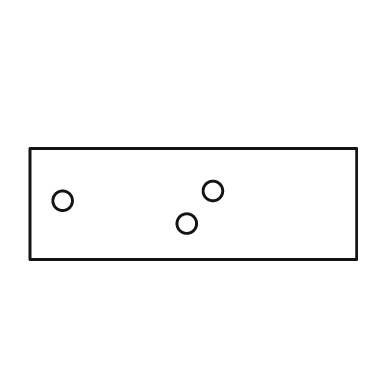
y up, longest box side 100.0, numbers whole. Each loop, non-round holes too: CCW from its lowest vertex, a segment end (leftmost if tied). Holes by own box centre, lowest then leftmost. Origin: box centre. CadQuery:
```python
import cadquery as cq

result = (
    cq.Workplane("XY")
    .moveTo(-50.0, -17.0)
    .lineTo(50.0, -17.0)
    .lineTo(50.0, 17.0)
    .lineTo(-50.0, 17.0)
    .close()
    .moveTo(-2.0, -6.0)
    .circle(3.0)
    .moveTo(-40.0, 1.0)
    .circle(3.0)
    .moveTo(6.0, 4.0)
    .circle(3.0)
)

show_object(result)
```